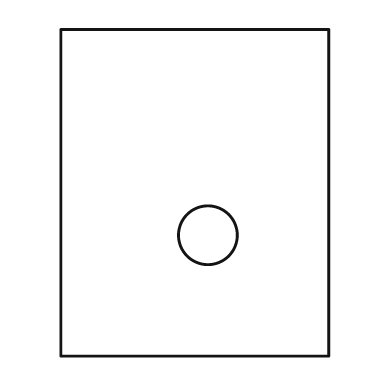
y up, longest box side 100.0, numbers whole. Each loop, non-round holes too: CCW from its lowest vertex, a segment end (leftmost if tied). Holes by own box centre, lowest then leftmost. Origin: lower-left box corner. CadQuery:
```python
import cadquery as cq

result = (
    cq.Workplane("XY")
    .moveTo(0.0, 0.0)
    .lineTo(82.0, 0.0)
    .lineTo(82.0, 100.0)
    .lineTo(0.0, 100.0)
    .close()
    .moveTo(45.0, 37.0)
    .circle(9.0)
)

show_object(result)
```